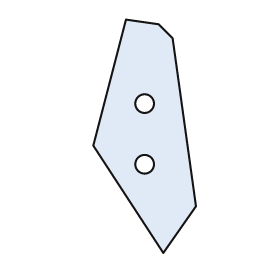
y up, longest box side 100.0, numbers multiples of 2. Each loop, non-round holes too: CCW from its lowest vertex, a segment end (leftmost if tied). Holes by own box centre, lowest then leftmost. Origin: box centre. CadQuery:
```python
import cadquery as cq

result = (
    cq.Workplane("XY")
    .moveTo(8.0, -50.0)
    .lineTo(22.0, -30.0)
    .lineTo(12.0, 42.0)
    .lineTo(6.0, 48.0)
    .lineTo(-8.0, 50.0)
    .lineTo(-22.0, -4.0)
    .close()
    .moveTo(0.0, -12.0)
    .circle(4.0)
    .moveTo(0.0, 14.0)
    .circle(4.0)
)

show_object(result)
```